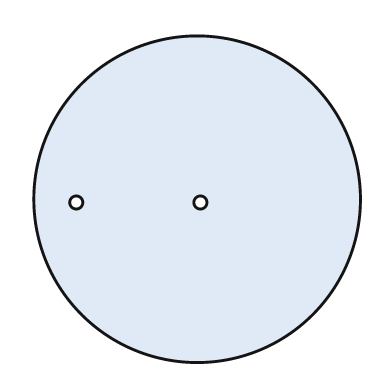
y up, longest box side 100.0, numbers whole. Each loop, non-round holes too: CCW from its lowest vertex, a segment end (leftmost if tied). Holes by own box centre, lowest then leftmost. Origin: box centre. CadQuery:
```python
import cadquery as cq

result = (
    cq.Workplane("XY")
    .moveTo(0.0, 0.0)
    .circle(50.0)
    .moveTo(-37.0, -1.0)
    .circle(2.0)
    .moveTo(1.0, -1.0)
    .circle(2.0)
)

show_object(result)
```